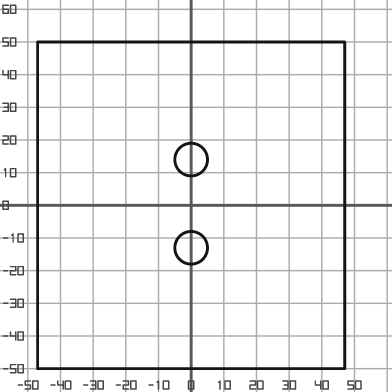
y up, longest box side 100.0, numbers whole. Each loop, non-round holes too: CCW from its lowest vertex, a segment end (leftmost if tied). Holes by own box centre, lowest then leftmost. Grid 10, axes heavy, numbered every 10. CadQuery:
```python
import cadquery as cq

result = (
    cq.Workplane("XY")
    .moveTo(-47.0, -50.0)
    .lineTo(47.0, -50.0)
    .lineTo(47.0, 50.0)
    .lineTo(-47.0, 50.0)
    .close()
    .moveTo(0.0, -13.0)
    .circle(5.0)
    .moveTo(0.0, 14.0)
    .circle(5.0)
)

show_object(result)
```